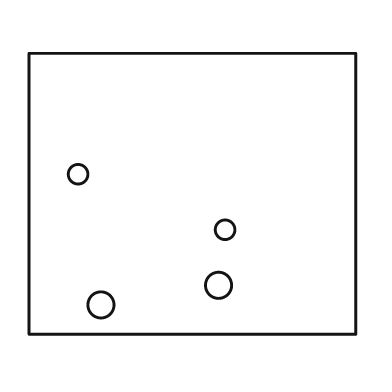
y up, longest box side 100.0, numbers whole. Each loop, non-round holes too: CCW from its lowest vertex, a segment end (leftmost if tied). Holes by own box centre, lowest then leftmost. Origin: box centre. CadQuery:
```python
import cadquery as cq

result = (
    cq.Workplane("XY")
    .moveTo(-50.0, -43.0)
    .lineTo(50.0, -43.0)
    .lineTo(50.0, 43.0)
    .lineTo(-50.0, 43.0)
    .close()
    .moveTo(-28.0, -34.0)
    .circle(4.0)
    .moveTo(8.0, -28.0)
    .circle(4.0)
    .moveTo(10.0, -11.0)
    .circle(3.0)
    .moveTo(-35.0, 6.0)
    .circle(3.0)
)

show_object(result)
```